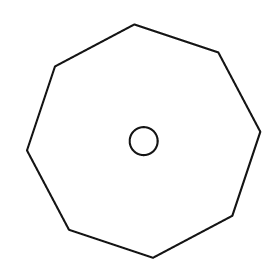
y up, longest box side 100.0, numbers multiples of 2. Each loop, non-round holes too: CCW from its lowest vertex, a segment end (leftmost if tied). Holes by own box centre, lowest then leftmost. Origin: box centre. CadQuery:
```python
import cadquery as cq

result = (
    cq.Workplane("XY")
    .moveTo(4.0, -50.0)
    .lineTo(38.0, -32.0)
    .lineTo(50.0, 4.0)
    .lineTo(32.0, 38.0)
    .lineTo(-4.0, 50.0)
    .lineTo(-38.0, 32.0)
    .lineTo(-50.0, -4.0)
    .lineTo(-32.0, -38.0)
    .close()
    .moveTo(0.0, 0.0)
    .circle(6.0)
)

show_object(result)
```